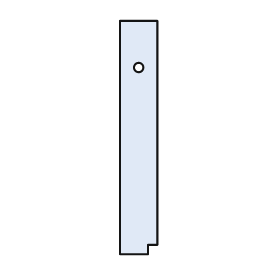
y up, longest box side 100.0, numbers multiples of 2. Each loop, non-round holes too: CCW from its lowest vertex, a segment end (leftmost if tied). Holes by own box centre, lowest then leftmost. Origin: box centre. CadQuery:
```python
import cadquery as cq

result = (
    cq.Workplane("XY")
    .moveTo(-8.0, -50.0)
    .lineTo(4.0, -50.0)
    .lineTo(4.0, -46.0)
    .lineTo(8.0, -46.0)
    .lineTo(8.0, 50.0)
    .lineTo(-8.0, 50.0)
    .close()
    .moveTo(0.0, 30.0)
    .circle(2.0)
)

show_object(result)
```